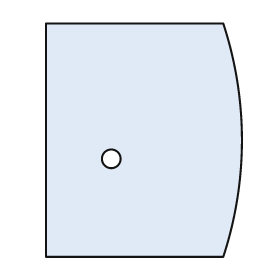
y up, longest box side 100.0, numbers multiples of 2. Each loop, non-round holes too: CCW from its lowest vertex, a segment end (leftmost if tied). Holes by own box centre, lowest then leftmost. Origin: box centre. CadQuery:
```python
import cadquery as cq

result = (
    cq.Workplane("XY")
    .moveTo(-42.0, -50.0)
    .lineTo(34.0, -50.0)
    .threePointArc((42.0, 0.0), (34.0, 50.0))
    .lineTo(-42.0, 50.0)
    .close()
    .moveTo(-14.0, -8.0)
    .circle(4.0)
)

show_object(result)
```